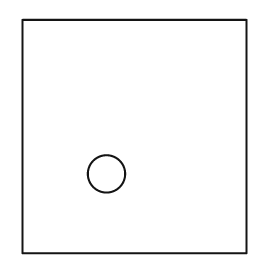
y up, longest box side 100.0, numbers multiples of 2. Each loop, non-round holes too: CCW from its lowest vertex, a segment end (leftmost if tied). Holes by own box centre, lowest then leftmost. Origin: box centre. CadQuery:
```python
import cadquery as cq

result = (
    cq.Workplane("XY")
    .moveTo(-48.0, -50.0)
    .lineTo(48.0, -50.0)
    .lineTo(48.0, 50.0)
    .lineTo(-48.0, 50.0)
    .close()
    .moveTo(-12.0, -16.0)
    .circle(8.0)
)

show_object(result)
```